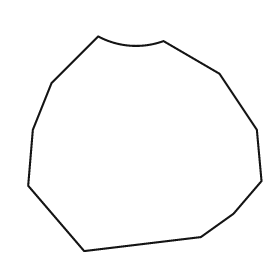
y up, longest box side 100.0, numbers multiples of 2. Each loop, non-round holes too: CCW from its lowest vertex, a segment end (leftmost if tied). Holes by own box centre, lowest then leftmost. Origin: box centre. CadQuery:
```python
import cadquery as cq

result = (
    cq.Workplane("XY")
    .moveTo(-26.0, -46.0)
    .lineTo(24.0, -40.0)
    .lineTo(38.0, -30.0)
    .lineTo(50.0, -16.0)
    .lineTo(48.0, 6.0)
    .lineTo(32.0, 30.0)
    .lineTo(8.0, 44.0)
    .threePointArc((-6.0, 42.0), (-20.0, 46.0))
    .lineTo(-40.0, 26.0)
    .lineTo(-48.0, 6.0)
    .lineTo(-50.0, -18.0)
    .close()
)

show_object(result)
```